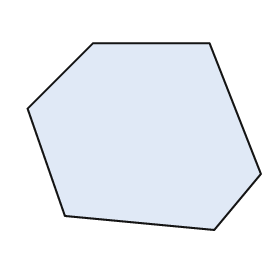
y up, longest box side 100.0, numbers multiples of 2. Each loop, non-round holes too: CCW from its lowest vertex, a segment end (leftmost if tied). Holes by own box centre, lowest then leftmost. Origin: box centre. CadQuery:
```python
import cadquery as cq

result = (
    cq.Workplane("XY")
    .moveTo(30.0, -40.0)
    .lineTo(50.0, -16.0)
    .lineTo(28.0, 40.0)
    .lineTo(-22.0, 40.0)
    .lineTo(-50.0, 12.0)
    .lineTo(-34.0, -34.0)
    .close()
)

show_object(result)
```